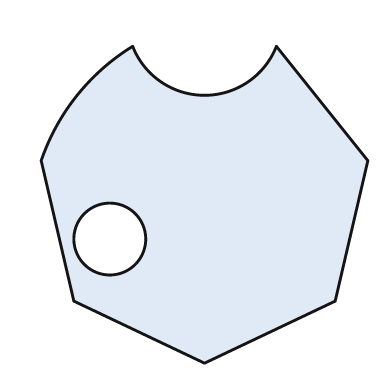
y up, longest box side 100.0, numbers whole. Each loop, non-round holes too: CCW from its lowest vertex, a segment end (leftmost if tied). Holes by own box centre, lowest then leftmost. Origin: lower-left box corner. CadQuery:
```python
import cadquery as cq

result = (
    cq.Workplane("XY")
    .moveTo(50.0, 0.0)
    .lineTo(90.0, 19.0)
    .lineTo(100.0, 62.0)
    .lineTo(72.0, 97.0)
    .threePointArc((50.0, 82.0), (28.0, 97.0))
    .threePointArc((11.0, 82.0), (0.0, 62.0))
    .lineTo(10.0, 19.0)
    .close()
    .moveTo(21.0, 38.0)
    .circle(11.0)
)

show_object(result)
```